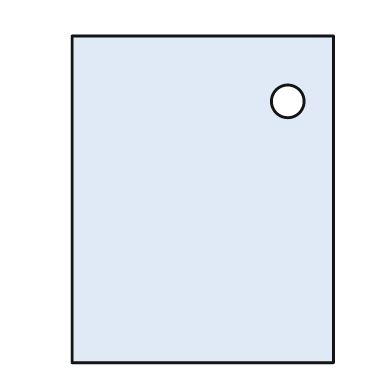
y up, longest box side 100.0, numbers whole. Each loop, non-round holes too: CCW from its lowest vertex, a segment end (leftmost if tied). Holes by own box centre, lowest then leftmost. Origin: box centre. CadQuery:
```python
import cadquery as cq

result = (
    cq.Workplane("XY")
    .moveTo(-40.0, -50.0)
    .lineTo(40.0, -50.0)
    .lineTo(40.0, 50.0)
    .lineTo(-40.0, 50.0)
    .close()
    .moveTo(26.0, 30.0)
    .circle(5.0)
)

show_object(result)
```